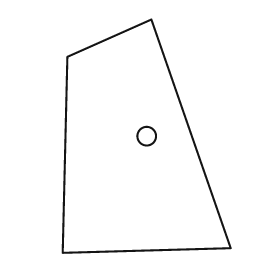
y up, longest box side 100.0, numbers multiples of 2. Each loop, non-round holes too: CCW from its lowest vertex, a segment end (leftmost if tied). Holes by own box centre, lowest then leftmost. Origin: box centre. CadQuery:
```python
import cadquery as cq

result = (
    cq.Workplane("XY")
    .moveTo(-36.0, -50.0)
    .lineTo(36.0, -48.0)
    .lineTo(2.0, 50.0)
    .lineTo(-34.0, 34.0)
    .close()
    .moveTo(0.0, 0.0)
    .circle(4.0)
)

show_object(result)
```